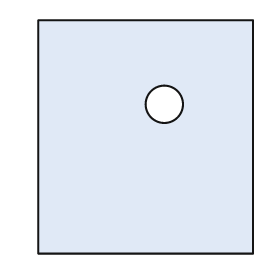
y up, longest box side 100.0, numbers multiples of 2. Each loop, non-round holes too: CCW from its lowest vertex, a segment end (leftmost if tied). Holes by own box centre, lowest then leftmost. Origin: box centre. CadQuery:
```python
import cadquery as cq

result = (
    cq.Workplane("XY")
    .moveTo(-46.0, -50.0)
    .lineTo(46.0, -50.0)
    .lineTo(46.0, 50.0)
    .lineTo(-46.0, 50.0)
    .close()
    .moveTo(8.0, 14.0)
    .circle(8.0)
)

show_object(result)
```